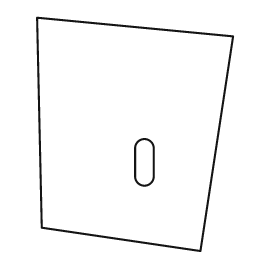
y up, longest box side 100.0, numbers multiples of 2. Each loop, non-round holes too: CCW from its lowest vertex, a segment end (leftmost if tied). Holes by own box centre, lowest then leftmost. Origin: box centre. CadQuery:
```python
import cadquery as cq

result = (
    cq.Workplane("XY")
    .moveTo(28.0, -50.0)
    .lineTo(42.0, 42.0)
    .lineTo(-42.0, 50.0)
    .lineTo(-40.0, -40.0)
    .close()
    .moveTo(0.0, -18.0)
    .threePointArc((4.0, -22.0), (8.0, -18.0))
    .lineTo(8.0, -6.0)
    .threePointArc((4.0, -2.0), (0.0, -6.0))
    .close()
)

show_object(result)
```